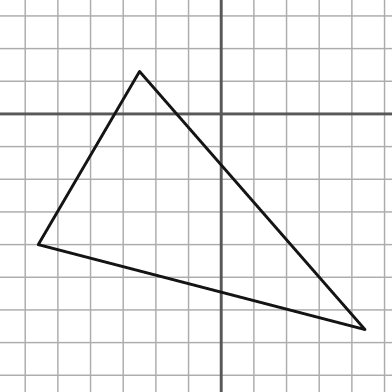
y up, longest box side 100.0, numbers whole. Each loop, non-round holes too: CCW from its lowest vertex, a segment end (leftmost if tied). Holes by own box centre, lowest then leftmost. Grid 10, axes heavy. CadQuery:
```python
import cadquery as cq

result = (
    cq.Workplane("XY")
    .moveTo(44.0, -66.0)
    .lineTo(-25.0, 13.0)
    .lineTo(-56.0, -40.0)
    .close()
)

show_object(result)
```